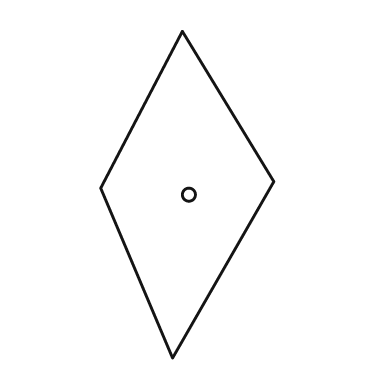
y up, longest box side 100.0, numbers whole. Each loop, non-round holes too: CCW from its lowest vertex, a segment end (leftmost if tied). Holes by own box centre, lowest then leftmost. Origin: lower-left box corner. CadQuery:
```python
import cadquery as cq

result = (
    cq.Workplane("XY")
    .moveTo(22.0, 0.0)
    .lineTo(53.0, 54.0)
    .lineTo(25.0, 100.0)
    .lineTo(0.0, 52.0)
    .close()
    .moveTo(27.0, 50.0)
    .circle(2.0)
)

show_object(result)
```